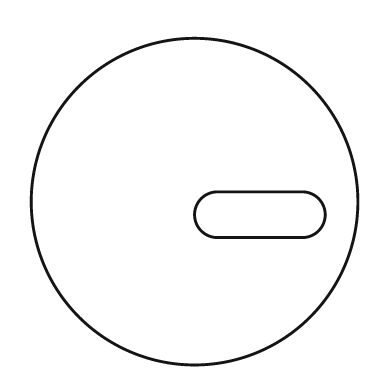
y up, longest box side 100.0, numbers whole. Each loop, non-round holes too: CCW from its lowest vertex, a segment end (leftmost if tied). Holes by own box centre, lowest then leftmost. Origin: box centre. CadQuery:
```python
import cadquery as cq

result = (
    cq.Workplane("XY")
    .moveTo(0.0, 0.0)
    .circle(50.0)
    .moveTo(7.0, -11.0)
    .lineTo(33.0, -11.0)
    .threePointArc((40.0, -4.0), (33.0, 3.0))
    .lineTo(7.0, 3.0)
    .threePointArc((0.0, -4.0), (7.0, -11.0))
    .close()
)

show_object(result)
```